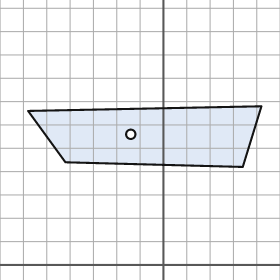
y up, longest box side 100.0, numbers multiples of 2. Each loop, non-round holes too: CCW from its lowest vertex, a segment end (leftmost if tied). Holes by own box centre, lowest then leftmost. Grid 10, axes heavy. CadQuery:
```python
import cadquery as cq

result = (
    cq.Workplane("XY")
    .moveTo(34.0, 42.0)
    .lineTo(42.0, 68.0)
    .lineTo(-58.0, 66.0)
    .lineTo(-42.0, 44.0)
    .close()
    .moveTo(-14.0, 56.0)
    .circle(2.0)
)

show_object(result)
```